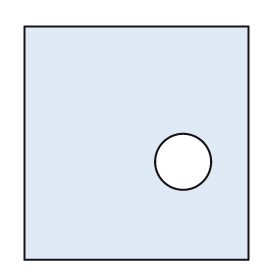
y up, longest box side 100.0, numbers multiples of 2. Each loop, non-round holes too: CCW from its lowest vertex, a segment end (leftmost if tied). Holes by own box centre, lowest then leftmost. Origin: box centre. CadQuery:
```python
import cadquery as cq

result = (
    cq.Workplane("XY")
    .moveTo(-48.0, -50.0)
    .lineTo(48.0, -50.0)
    .lineTo(48.0, 50.0)
    .lineTo(-48.0, 50.0)
    .close()
    .moveTo(20.0, -8.0)
    .circle(12.0)
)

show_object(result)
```